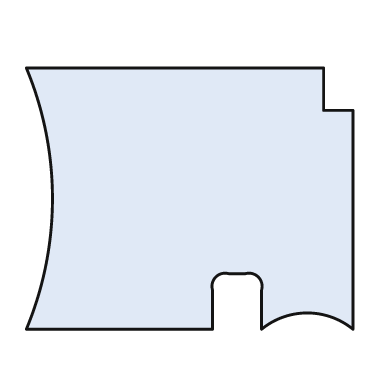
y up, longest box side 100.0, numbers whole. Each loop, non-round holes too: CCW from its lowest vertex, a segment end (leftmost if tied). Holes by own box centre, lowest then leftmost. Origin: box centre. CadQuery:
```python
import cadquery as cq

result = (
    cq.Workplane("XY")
    .moveTo(-50.0, -40.0)
    .lineTo(7.0, -40.0)
    .lineTo(7.0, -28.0)
    .threePointArc((8.0, -24.0), (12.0, -23.0))
    .lineTo(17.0, -23.0)
    .threePointArc((21.0, -24.0), (22.0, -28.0))
    .lineTo(22.0, -40.0)
    .threePointArc((36.0, -35.0), (50.0, -40.0))
    .lineTo(50.0, 27.0)
    .lineTo(41.0, 27.0)
    .lineTo(41.0, 40.0)
    .lineTo(-50.0, 40.0)
    .threePointArc((-42.0, 0.0), (-50.0, -40.0))
    .close()
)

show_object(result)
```